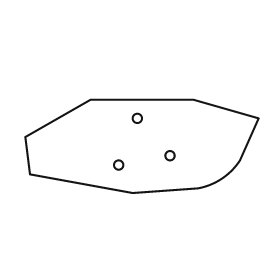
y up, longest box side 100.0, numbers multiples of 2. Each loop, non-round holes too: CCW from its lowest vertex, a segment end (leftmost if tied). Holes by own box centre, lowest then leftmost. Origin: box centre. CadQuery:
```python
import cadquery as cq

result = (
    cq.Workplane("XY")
    .moveTo(-4.0, -20.0)
    .lineTo(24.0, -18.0)
    .threePointArc((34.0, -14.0), (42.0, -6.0))
    .lineTo(50.0, 12.0)
    .lineTo(22.0, 20.0)
    .lineTo(-22.0, 20.0)
    .lineTo(-50.0, 4.0)
    .lineTo(-48.0, -12.0)
    .close()
    .moveTo(-10.0, -8.0)
    .circle(2.0)
    .moveTo(12.0, -4.0)
    .circle(2.0)
    .moveTo(-2.0, 12.0)
    .circle(2.0)
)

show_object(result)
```